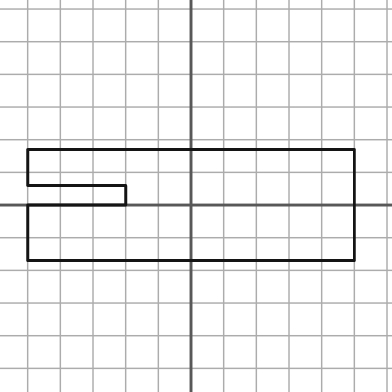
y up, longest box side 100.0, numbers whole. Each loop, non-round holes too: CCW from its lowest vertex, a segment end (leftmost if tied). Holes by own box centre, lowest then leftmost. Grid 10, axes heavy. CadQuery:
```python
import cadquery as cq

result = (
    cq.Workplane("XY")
    .moveTo(-50.0, -17.0)
    .lineTo(50.0, -17.0)
    .lineTo(50.0, 17.0)
    .lineTo(-50.0, 17.0)
    .lineTo(-50.0, 6.0)
    .lineTo(-20.0, 6.0)
    .lineTo(-20.0, 0.0)
    .lineTo(-50.0, 0.0)
    .close()
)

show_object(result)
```